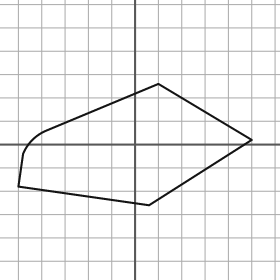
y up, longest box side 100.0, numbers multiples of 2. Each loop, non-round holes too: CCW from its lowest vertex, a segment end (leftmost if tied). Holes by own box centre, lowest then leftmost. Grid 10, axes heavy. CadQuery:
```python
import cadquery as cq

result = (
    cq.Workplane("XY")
    .moveTo(6.0, -26.0)
    .lineTo(50.0, 2.0)
    .lineTo(10.0, 26.0)
    .lineTo(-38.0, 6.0)
    .threePointArc((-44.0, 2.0), (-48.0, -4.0))
    .lineTo(-50.0, -18.0)
    .close()
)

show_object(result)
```